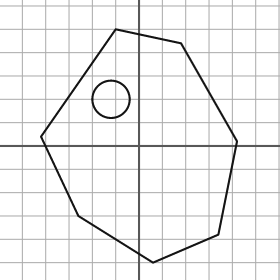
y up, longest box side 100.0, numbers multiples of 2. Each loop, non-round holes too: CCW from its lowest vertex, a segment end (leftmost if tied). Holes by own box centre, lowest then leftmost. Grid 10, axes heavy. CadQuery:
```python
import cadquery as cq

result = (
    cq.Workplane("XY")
    .moveTo(6.0, -50.0)
    .lineTo(34.0, -38.0)
    .lineTo(42.0, 2.0)
    .lineTo(18.0, 44.0)
    .lineTo(-10.0, 50.0)
    .lineTo(-42.0, 4.0)
    .lineTo(-26.0, -30.0)
    .close()
    .moveTo(-12.0, 20.0)
    .circle(8.0)
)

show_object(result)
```